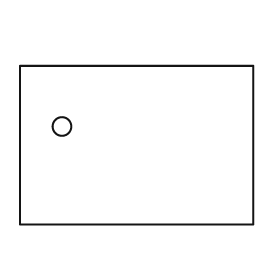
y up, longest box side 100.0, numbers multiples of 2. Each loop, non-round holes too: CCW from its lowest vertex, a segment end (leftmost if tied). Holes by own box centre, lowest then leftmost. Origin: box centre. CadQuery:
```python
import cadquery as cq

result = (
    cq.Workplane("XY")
    .moveTo(-50.0, -34.0)
    .lineTo(50.0, -34.0)
    .lineTo(50.0, 34.0)
    .lineTo(-50.0, 34.0)
    .close()
    .moveTo(-32.0, 8.0)
    .circle(4.0)
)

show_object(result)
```